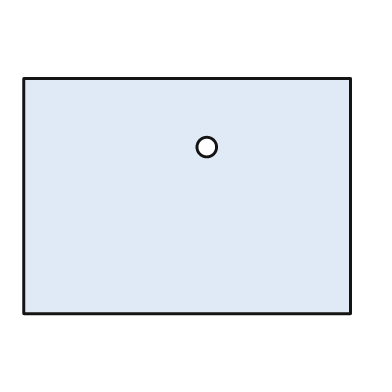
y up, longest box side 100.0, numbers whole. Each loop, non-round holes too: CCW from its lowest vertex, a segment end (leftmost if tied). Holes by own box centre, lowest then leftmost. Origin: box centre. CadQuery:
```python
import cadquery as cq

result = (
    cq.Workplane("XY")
    .moveTo(-50.0, -36.0)
    .lineTo(50.0, -36.0)
    .lineTo(50.0, 36.0)
    .lineTo(-50.0, 36.0)
    .close()
    .moveTo(6.0, 15.0)
    .circle(3.0)
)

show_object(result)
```